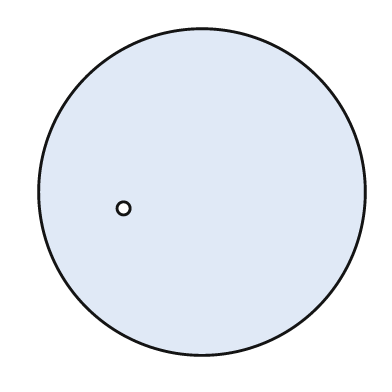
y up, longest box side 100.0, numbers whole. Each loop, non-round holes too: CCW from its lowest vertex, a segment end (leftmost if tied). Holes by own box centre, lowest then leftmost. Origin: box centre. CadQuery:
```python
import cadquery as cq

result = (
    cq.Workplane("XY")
    .moveTo(0.0, 0.0)
    .circle(50.0)
    .moveTo(-24.0, -5.0)
    .circle(2.0)
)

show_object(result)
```